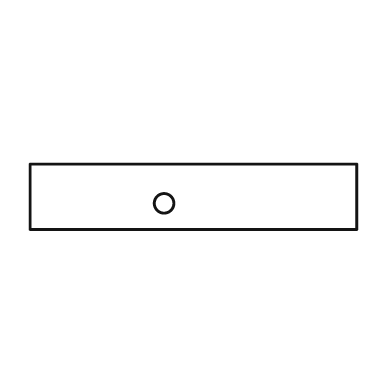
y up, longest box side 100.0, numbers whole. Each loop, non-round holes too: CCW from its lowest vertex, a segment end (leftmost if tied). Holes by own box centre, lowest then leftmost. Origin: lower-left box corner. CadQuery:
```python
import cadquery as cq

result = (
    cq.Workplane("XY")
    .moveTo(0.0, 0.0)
    .lineTo(100.0, 0.0)
    .lineTo(100.0, 20.0)
    .lineTo(0.0, 20.0)
    .close()
    .moveTo(41.0, 8.0)
    .circle(3.0)
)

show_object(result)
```